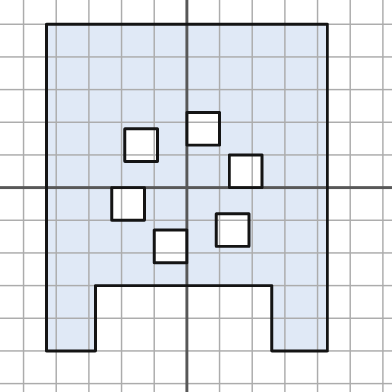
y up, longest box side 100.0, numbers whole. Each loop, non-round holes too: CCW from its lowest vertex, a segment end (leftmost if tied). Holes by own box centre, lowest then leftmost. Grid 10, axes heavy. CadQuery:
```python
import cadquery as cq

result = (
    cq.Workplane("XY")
    .moveTo(-43.0, -50.0)
    .lineTo(-28.0, -50.0)
    .lineTo(-28.0, -30.0)
    .lineTo(26.0, -30.0)
    .lineTo(26.0, -50.0)
    .lineTo(43.0, -50.0)
    .lineTo(43.0, 50.0)
    .lineTo(-43.0, 50.0)
    .close()
    .moveTo(-10.0, -23.0)
    .lineTo(0.0, -23.0)
    .lineTo(0.0, -13.0)
    .lineTo(-10.0, -13.0)
    .close()
    .moveTo(9.0, -18.0)
    .lineTo(19.0, -18.0)
    .lineTo(19.0, -8.0)
    .lineTo(9.0, -8.0)
    .close()
    .moveTo(-23.0, -10.0)
    .lineTo(-13.0, -10.0)
    .lineTo(-13.0, 0.0)
    .lineTo(-23.0, 0.0)
    .close()
    .moveTo(13.0, 0.0)
    .lineTo(23.0, 0.0)
    .lineTo(23.0, 10.0)
    .lineTo(13.0, 10.0)
    .close()
    .moveTo(-19.0, 8.0)
    .lineTo(-9.0, 8.0)
    .lineTo(-9.0, 18.0)
    .lineTo(-19.0, 18.0)
    .close()
    .moveTo(0.0, 13.0)
    .lineTo(10.0, 13.0)
    .lineTo(10.0, 23.0)
    .lineTo(0.0, 23.0)
    .close()
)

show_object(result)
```